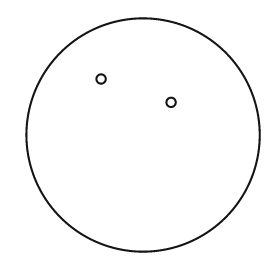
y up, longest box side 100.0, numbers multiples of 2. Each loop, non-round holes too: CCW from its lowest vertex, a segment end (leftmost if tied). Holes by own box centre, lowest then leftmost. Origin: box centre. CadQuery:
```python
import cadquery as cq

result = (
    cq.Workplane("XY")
    .moveTo(0.0, 0.0)
    .circle(50.0)
    .moveTo(12.0, 14.0)
    .circle(2.0)
    .moveTo(-18.0, 24.0)
    .circle(2.0)
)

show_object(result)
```